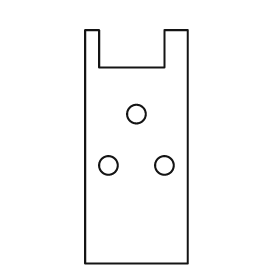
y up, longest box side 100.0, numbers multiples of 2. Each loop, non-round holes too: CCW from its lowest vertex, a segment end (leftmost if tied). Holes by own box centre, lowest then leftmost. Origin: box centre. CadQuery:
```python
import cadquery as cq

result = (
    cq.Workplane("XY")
    .moveTo(-22.0, -50.0)
    .lineTo(22.0, -50.0)
    .lineTo(22.0, 50.0)
    .lineTo(12.0, 50.0)
    .lineTo(12.0, 34.0)
    .lineTo(-16.0, 34.0)
    .lineTo(-16.0, 50.0)
    .lineTo(-22.0, 50.0)
    .close()
    .moveTo(-12.0, -8.0)
    .circle(4.0)
    .moveTo(12.0, -8.0)
    .circle(4.0)
    .moveTo(0.0, 14.0)
    .circle(4.0)
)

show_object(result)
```